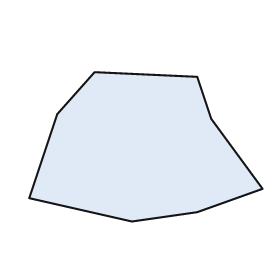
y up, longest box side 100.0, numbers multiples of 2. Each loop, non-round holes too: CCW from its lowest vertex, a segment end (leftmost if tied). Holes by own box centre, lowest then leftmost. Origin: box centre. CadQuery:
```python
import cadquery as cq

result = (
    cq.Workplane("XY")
    .moveTo(-6.0, -32.0)
    .lineTo(22.0, -28.0)
    .lineTo(50.0, -18.0)
    .lineTo(28.0, 12.0)
    .lineTo(22.0, 30.0)
    .lineTo(-22.0, 32.0)
    .lineTo(-38.0, 14.0)
    .lineTo(-50.0, -22.0)
    .close()
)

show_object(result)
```